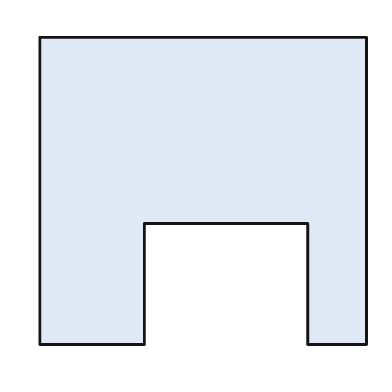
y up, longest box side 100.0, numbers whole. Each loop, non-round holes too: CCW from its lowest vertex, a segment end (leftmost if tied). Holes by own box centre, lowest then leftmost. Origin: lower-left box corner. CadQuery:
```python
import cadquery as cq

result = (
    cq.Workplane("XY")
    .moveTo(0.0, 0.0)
    .lineTo(32.0, 0.0)
    .lineTo(32.0, 37.0)
    .lineTo(82.0, 37.0)
    .lineTo(82.0, 0.0)
    .lineTo(100.0, 0.0)
    .lineTo(100.0, 94.0)
    .lineTo(0.0, 94.0)
    .close()
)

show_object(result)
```